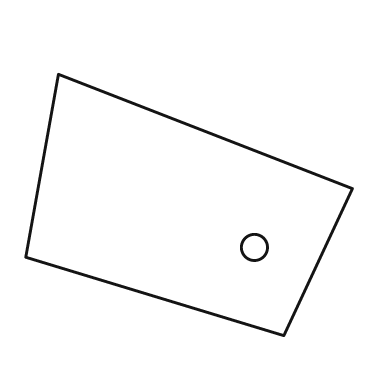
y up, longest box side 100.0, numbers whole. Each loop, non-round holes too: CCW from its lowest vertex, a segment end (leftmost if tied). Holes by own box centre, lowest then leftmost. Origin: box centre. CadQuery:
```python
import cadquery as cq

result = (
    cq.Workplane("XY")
    .moveTo(29.0, -40.0)
    .lineTo(50.0, 5.0)
    .lineTo(-40.0, 40.0)
    .lineTo(-50.0, -16.0)
    .close()
    .moveTo(20.0, -13.0)
    .circle(4.0)
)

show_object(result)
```